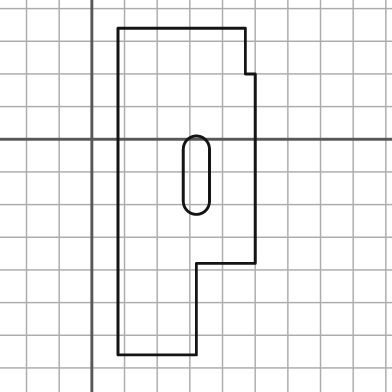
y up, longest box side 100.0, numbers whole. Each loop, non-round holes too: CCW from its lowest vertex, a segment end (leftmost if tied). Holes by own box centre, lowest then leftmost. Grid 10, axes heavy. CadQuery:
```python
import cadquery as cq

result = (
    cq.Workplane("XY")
    .moveTo(8.0, -66.0)
    .lineTo(32.0, -66.0)
    .lineTo(32.0, -38.0)
    .lineTo(50.0, -38.0)
    .lineTo(50.0, 20.0)
    .lineTo(47.0, 20.0)
    .lineTo(47.0, 34.0)
    .lineTo(8.0, 34.0)
    .close()
    .moveTo(28.0, -19.0)
    .threePointArc((32.0, -23.0), (36.0, -19.0))
    .lineTo(36.0, -3.0)
    .threePointArc((32.0, 1.0), (28.0, -3.0))
    .close()
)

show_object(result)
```